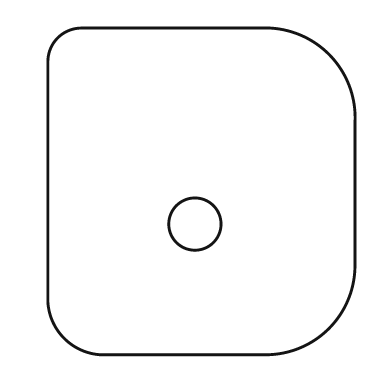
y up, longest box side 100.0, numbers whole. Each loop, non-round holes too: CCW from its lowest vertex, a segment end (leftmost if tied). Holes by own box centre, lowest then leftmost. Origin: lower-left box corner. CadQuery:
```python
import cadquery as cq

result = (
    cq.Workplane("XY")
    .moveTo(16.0, 0.0)
    .lineTo(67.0, 0.0)
    .threePointArc((86.0, 8.0), (94.0, 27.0))
    .lineTo(94.0, 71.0)
    .threePointArc((86.0, 92.0), (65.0, 100.0))
    .lineTo(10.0, 100.0)
    .threePointArc((3.0, 97.0), (0.0, 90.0))
    .lineTo(0.0, 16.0)
    .threePointArc((5.0, 5.0), (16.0, 0.0))
    .close()
    .moveTo(45.0, 40.0)
    .circle(8.0)
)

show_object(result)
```